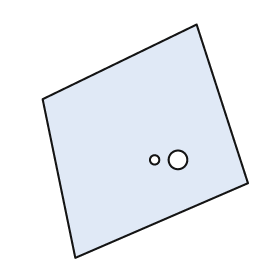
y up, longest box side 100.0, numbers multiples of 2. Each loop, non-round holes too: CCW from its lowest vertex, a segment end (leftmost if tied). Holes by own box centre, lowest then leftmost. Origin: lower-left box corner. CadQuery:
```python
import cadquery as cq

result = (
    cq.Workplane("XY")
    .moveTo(14.0, 0.0)
    .lineTo(88.0, 32.0)
    .lineTo(66.0, 100.0)
    .lineTo(0.0, 68.0)
    .close()
    .moveTo(48.0, 42.0)
    .circle(2.0)
    .moveTo(58.0, 42.0)
    .circle(4.0)
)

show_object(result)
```